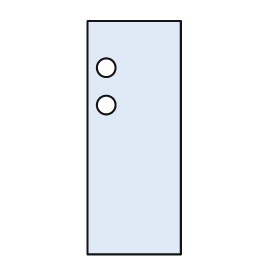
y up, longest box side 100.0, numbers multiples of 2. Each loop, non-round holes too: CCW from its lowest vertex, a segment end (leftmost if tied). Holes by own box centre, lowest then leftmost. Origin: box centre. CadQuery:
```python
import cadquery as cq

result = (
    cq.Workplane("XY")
    .moveTo(-20.0, -50.0)
    .lineTo(20.0, -50.0)
    .lineTo(20.0, 50.0)
    .lineTo(-20.0, 50.0)
    .close()
    .moveTo(-12.0, 14.0)
    .circle(4.0)
    .moveTo(-12.0, 30.0)
    .circle(4.0)
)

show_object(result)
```